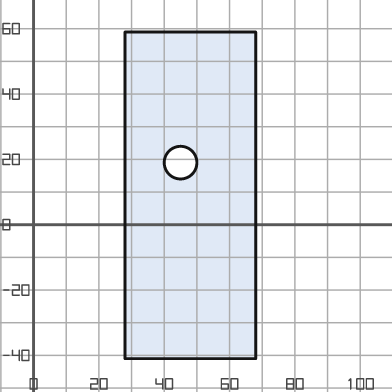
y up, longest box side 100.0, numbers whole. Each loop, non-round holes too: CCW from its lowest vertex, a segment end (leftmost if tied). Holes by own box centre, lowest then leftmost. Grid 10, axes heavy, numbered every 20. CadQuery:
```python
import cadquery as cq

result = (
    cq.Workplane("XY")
    .moveTo(28.0, -41.0)
    .lineTo(68.0, -41.0)
    .lineTo(68.0, 59.0)
    .lineTo(28.0, 59.0)
    .close()
    .moveTo(45.0, 19.0)
    .circle(5.0)
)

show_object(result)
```